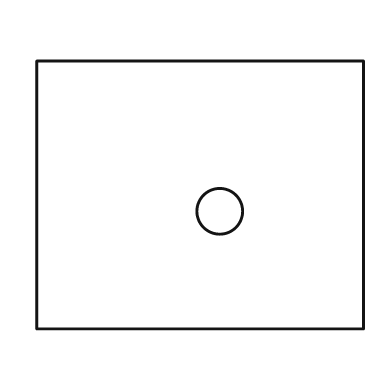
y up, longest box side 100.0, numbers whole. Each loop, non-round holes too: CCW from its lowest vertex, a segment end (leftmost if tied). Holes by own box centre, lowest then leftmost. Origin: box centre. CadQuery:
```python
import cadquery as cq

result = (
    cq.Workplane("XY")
    .moveTo(-50.0, -41.0)
    .lineTo(50.0, -41.0)
    .lineTo(50.0, 41.0)
    .lineTo(-50.0, 41.0)
    .close()
    .moveTo(6.0, -5.0)
    .circle(7.0)
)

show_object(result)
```